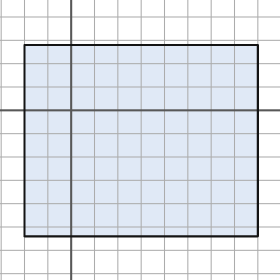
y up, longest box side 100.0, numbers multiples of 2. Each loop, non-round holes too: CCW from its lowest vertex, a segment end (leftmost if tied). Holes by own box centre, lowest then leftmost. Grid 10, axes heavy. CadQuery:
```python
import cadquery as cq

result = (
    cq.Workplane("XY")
    .moveTo(-20.0, -54.0)
    .lineTo(80.0, -54.0)
    .lineTo(80.0, 28.0)
    .lineTo(-20.0, 28.0)
    .close()
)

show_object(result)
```